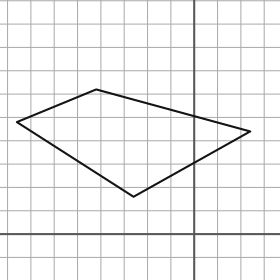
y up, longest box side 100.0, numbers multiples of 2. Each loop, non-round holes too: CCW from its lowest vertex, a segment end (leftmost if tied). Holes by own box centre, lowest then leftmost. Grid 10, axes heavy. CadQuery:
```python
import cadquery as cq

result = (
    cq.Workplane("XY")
    .moveTo(-26.0, 16.0)
    .lineTo(24.0, 44.0)
    .lineTo(-42.0, 62.0)
    .lineTo(-76.0, 48.0)
    .close()
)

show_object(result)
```